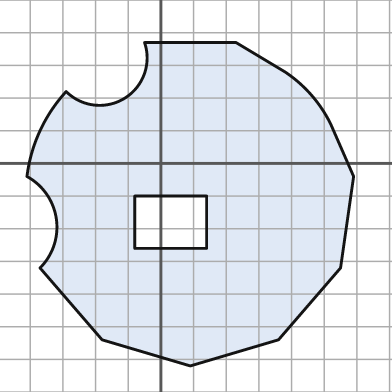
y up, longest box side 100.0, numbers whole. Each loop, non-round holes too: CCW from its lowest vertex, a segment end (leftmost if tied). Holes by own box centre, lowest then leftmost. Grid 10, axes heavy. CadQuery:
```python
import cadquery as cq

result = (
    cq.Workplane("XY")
    .moveTo(9.0, -62.0)
    .lineTo(36.0, -54.0)
    .lineTo(55.0, -32.0)
    .lineTo(59.0, -4.0)
    .lineTo(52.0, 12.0)
    .threePointArc((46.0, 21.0), (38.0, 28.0))
    .lineTo(23.0, 37.0)
    .lineTo(-5.0, 37.0)
    .threePointArc((-11.0, 20.0), (-29.0, 22.0))
    .threePointArc((-37.0, 10.0), (-41.0, -4.0))
    .threePointArc((-32.0, -17.0), (-37.0, -32.0))
    .lineTo(-18.0, -54.0)
    .close()
    .moveTo(-8.0, -26.0)
    .lineTo(14.0, -26.0)
    .lineTo(14.0, -10.0)
    .lineTo(-8.0, -10.0)
    .close()
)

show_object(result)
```